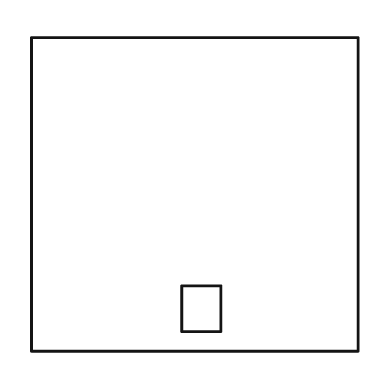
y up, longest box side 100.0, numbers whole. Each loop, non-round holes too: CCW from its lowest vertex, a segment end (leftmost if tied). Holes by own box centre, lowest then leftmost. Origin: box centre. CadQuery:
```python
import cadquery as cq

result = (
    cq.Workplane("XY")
    .moveTo(-50.0, -48.0)
    .lineTo(50.0, -48.0)
    .lineTo(50.0, 48.0)
    .lineTo(-50.0, 48.0)
    .close()
    .moveTo(-4.0, -42.0)
    .lineTo(8.0, -42.0)
    .lineTo(8.0, -28.0)
    .lineTo(-4.0, -28.0)
    .close()
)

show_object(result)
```